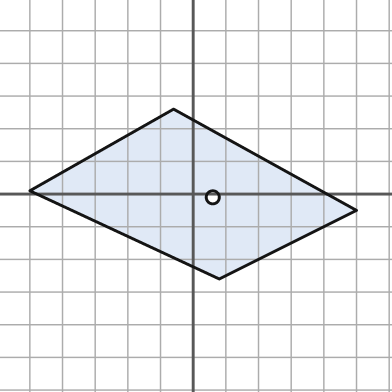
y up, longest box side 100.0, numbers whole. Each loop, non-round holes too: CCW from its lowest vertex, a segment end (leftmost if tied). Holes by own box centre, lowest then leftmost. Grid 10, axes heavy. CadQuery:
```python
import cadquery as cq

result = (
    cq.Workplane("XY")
    .moveTo(8.0, -26.0)
    .lineTo(50.0, -5.0)
    .lineTo(-6.0, 26.0)
    .lineTo(-50.0, 1.0)
    .close()
    .moveTo(6.0, -1.0)
    .circle(2.0)
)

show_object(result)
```